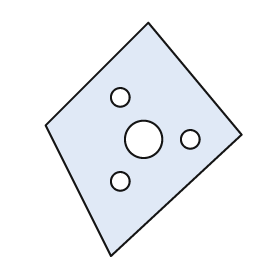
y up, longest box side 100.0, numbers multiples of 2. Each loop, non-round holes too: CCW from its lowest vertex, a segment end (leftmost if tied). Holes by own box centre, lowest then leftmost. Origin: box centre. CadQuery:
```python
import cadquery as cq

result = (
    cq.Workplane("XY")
    .moveTo(-14.0, -50.0)
    .lineTo(42.0, 2.0)
    .lineTo(2.0, 50.0)
    .lineTo(-42.0, 6.0)
    .close()
    .moveTo(-10.0, -18.0)
    .circle(4.0)
    .moveTo(0.0, 0.0)
    .circle(8.0)
    .moveTo(20.0, 0.0)
    .circle(4.0)
    .moveTo(-10.0, 18.0)
    .circle(4.0)
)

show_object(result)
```